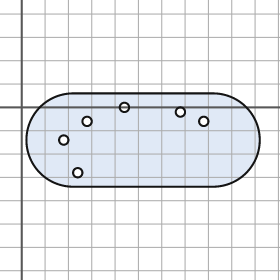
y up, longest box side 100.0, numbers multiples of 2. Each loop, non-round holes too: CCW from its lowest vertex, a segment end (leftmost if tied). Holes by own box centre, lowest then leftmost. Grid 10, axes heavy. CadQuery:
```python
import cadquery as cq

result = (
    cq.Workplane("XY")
    .moveTo(22.0, -34.0)
    .lineTo(82.0, -34.0)
    .threePointArc((102.0, -14.0), (82.0, 6.0))
    .lineTo(22.0, 6.0)
    .threePointArc((2.0, -14.0), (22.0, -34.0))
    .close()
    .moveTo(24.0, -28.0)
    .circle(2.0)
    .moveTo(18.0, -14.0)
    .circle(2.0)
    .moveTo(28.0, -6.0)
    .circle(2.0)
    .moveTo(78.0, -6.0)
    .circle(2.0)
    .moveTo(68.0, -2.0)
    .circle(2.0)
    .moveTo(44.0, 0.0)
    .circle(2.0)
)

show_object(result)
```